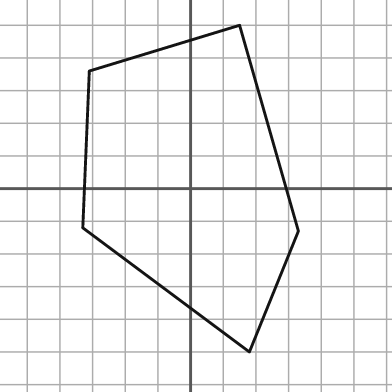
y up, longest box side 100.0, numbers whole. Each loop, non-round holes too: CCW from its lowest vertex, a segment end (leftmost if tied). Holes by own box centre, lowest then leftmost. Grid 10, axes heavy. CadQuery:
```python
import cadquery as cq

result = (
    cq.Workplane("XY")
    .moveTo(18.0, -50.0)
    .lineTo(33.0, -13.0)
    .lineTo(15.0, 50.0)
    .lineTo(-31.0, 36.0)
    .lineTo(-33.0, -12.0)
    .close()
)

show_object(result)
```